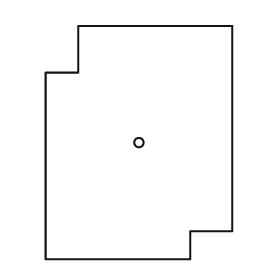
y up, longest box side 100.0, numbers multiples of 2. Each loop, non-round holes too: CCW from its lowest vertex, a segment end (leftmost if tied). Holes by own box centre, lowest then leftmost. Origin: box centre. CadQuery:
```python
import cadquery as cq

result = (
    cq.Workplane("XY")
    .moveTo(-40.0, -50.0)
    .lineTo(22.0, -50.0)
    .lineTo(22.0, -38.0)
    .lineTo(40.0, -38.0)
    .lineTo(40.0, 50.0)
    .lineTo(-26.0, 50.0)
    .lineTo(-26.0, 30.0)
    .lineTo(-40.0, 30.0)
    .close()
    .moveTo(0.0, 0.0)
    .circle(2.0)
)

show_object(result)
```